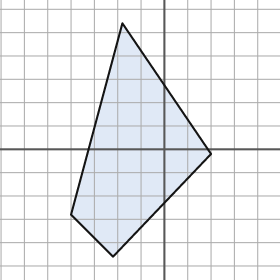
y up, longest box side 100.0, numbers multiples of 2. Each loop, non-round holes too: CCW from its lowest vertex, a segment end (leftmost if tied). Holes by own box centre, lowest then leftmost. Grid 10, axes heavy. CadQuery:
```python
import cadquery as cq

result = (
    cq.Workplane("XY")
    .moveTo(-22.0, -46.0)
    .lineTo(20.0, -2.0)
    .lineTo(-18.0, 54.0)
    .lineTo(-40.0, -28.0)
    .close()
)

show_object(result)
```